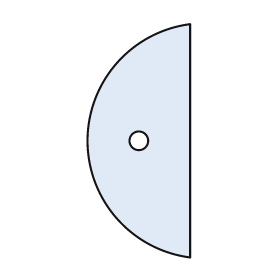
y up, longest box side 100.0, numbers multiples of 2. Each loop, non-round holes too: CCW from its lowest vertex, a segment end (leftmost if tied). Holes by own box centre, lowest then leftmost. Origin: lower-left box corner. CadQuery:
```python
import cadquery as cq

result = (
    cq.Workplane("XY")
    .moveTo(44.0, 0.0)
    .lineTo(44.0, 100.0)
    .threePointArc((0.0, 50.0), (44.0, 0.0))
    .close()
    .moveTo(22.0, 50.0)
    .circle(4.0)
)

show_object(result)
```